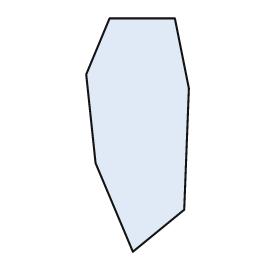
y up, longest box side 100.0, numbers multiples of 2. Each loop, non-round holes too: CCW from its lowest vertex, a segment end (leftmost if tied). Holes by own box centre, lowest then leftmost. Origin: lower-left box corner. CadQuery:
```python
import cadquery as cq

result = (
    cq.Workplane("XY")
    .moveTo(20.0, 0.0)
    .lineTo(42.0, 18.0)
    .lineTo(44.0, 70.0)
    .lineTo(38.0, 100.0)
    .lineTo(10.0, 100.0)
    .lineTo(0.0, 76.0)
    .lineTo(4.0, 38.0)
    .close()
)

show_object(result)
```